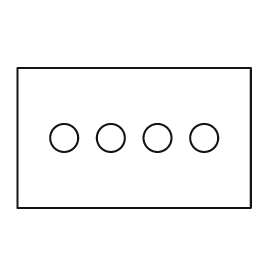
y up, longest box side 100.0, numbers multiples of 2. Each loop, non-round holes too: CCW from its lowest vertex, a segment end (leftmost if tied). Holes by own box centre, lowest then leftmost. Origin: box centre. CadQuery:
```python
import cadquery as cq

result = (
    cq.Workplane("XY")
    .moveTo(-50.0, -30.0)
    .lineTo(50.0, -30.0)
    .lineTo(50.0, 30.0)
    .lineTo(-50.0, 30.0)
    .close()
    .moveTo(-30.0, 0.0)
    .circle(6.0)
    .moveTo(-10.0, 0.0)
    .circle(6.0)
    .moveTo(10.0, 0.0)
    .circle(6.0)
    .moveTo(30.0, 0.0)
    .circle(6.0)
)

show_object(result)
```